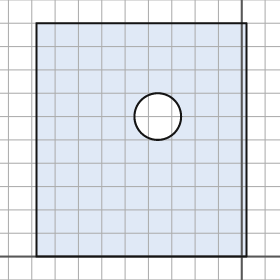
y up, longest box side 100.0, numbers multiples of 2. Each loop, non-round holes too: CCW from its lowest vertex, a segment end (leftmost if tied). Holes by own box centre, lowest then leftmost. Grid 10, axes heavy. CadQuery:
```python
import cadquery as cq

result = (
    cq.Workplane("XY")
    .moveTo(-88.0, 0.0)
    .lineTo(2.0, 0.0)
    .lineTo(2.0, 100.0)
    .lineTo(-88.0, 100.0)
    .close()
    .moveTo(-36.0, 60.0)
    .circle(10.0)
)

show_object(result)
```